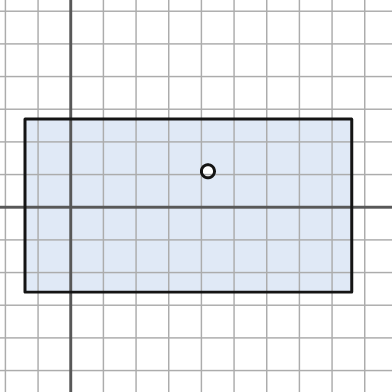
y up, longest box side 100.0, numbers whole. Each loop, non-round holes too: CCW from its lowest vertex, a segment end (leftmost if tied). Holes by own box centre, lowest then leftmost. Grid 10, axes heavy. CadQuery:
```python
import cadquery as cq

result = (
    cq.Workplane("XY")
    .moveTo(-14.0, -26.0)
    .lineTo(86.0, -26.0)
    .lineTo(86.0, 27.0)
    .lineTo(-14.0, 27.0)
    .close()
    .moveTo(42.0, 11.0)
    .circle(2.0)
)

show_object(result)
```